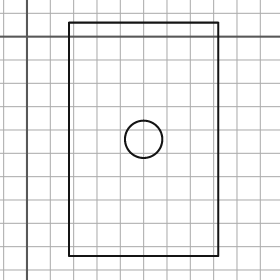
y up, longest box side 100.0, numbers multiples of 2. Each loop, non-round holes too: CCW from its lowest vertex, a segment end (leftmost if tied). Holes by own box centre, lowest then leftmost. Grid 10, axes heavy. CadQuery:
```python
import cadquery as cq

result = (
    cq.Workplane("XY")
    .moveTo(18.0, -94.0)
    .lineTo(82.0, -94.0)
    .lineTo(82.0, 6.0)
    .lineTo(18.0, 6.0)
    .close()
    .moveTo(50.0, -44.0)
    .circle(8.0)
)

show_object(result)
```